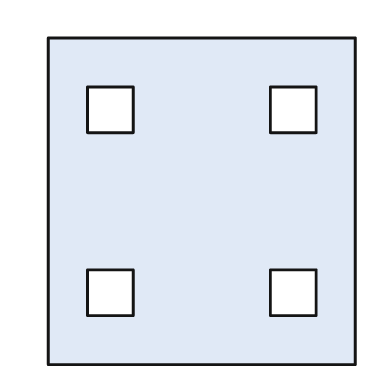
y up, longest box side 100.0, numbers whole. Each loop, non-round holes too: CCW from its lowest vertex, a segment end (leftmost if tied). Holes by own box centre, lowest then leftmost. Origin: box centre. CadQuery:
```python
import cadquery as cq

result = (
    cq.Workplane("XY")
    .moveTo(-47.0, -50.0)
    .lineTo(47.0, -50.0)
    .lineTo(47.0, 50.0)
    .lineTo(-47.0, 50.0)
    .close()
    .moveTo(-35.0, -35.0)
    .lineTo(-21.0, -35.0)
    .lineTo(-21.0, -21.0)
    .lineTo(-35.0, -21.0)
    .close()
    .moveTo(21.0, -35.0)
    .lineTo(35.0, -35.0)
    .lineTo(35.0, -21.0)
    .lineTo(21.0, -21.0)
    .close()
    .moveTo(-35.0, 21.0)
    .lineTo(-21.0, 21.0)
    .lineTo(-21.0, 35.0)
    .lineTo(-35.0, 35.0)
    .close()
    .moveTo(21.0, 21.0)
    .lineTo(35.0, 21.0)
    .lineTo(35.0, 35.0)
    .lineTo(21.0, 35.0)
    .close()
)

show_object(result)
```